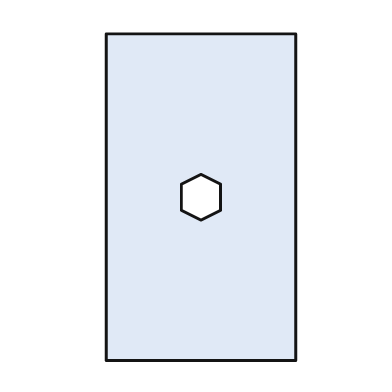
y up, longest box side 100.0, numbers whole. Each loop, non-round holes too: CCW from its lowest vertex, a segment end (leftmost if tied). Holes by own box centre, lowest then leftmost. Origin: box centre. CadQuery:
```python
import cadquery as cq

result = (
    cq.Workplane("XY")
    .moveTo(-29.0, -50.0)
    .lineTo(29.0, -50.0)
    .lineTo(29.0, 50.0)
    .lineTo(-29.0, 50.0)
    .close()
    .moveTo(0.0, -7.0)
    .lineTo(6.0, -4.0)
    .lineTo(6.0, 4.0)
    .lineTo(0.0, 7.0)
    .lineTo(-6.0, 4.0)
    .lineTo(-6.0, -4.0)
    .close()
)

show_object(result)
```